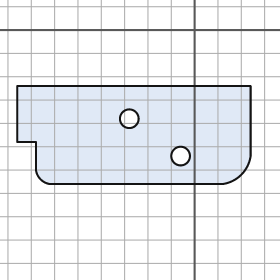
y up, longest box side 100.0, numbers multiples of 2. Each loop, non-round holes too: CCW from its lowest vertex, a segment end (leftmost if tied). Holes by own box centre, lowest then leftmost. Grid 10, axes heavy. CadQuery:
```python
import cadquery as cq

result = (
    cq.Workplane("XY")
    .moveTo(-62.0, -66.0)
    .lineTo(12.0, -66.0)
    .threePointArc((20.0, -62.0), (24.0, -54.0))
    .lineTo(24.0, -24.0)
    .lineTo(-76.0, -24.0)
    .lineTo(-76.0, -48.0)
    .lineTo(-68.0, -48.0)
    .lineTo(-68.0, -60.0)
    .threePointArc((-66.0, -64.0), (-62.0, -66.0))
    .close()
    .moveTo(-6.0, -54.0)
    .circle(4.0)
    .moveTo(-28.0, -38.0)
    .circle(4.0)
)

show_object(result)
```